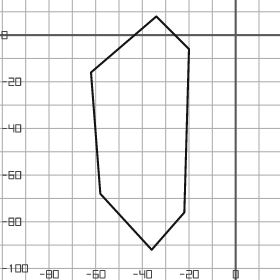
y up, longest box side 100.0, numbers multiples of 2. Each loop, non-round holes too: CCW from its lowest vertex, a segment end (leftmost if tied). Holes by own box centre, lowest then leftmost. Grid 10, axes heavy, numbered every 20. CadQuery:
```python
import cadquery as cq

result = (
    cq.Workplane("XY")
    .moveTo(-36.0, -92.0)
    .lineTo(-22.0, -76.0)
    .lineTo(-20.0, -6.0)
    .lineTo(-34.0, 8.0)
    .lineTo(-62.0, -16.0)
    .lineTo(-58.0, -68.0)
    .close()
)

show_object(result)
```